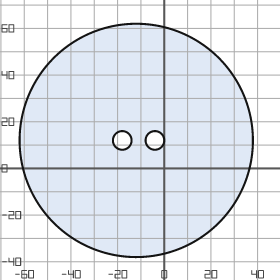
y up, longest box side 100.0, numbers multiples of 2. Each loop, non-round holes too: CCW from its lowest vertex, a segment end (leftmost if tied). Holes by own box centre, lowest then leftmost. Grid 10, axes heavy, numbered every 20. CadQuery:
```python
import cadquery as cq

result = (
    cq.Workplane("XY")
    .moveTo(-12.0, 12.0)
    .circle(50.0)
    .moveTo(-18.0, 12.0)
    .circle(4.0)
    .moveTo(-4.0, 12.0)
    .circle(4.0)
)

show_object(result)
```